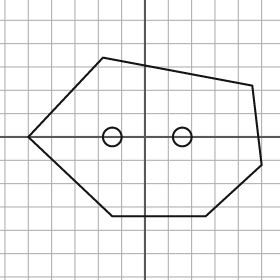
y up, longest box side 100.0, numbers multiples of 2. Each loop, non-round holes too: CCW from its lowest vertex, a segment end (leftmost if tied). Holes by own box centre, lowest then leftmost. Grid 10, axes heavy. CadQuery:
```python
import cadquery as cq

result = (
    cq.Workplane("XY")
    .moveTo(-14.0, -34.0)
    .lineTo(26.0, -34.0)
    .lineTo(50.0, -12.0)
    .lineTo(46.0, 22.0)
    .lineTo(-18.0, 34.0)
    .lineTo(-50.0, 0.0)
    .close()
    .moveTo(-14.0, 0.0)
    .circle(4.0)
    .moveTo(16.0, 0.0)
    .circle(4.0)
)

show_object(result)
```